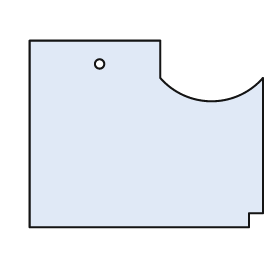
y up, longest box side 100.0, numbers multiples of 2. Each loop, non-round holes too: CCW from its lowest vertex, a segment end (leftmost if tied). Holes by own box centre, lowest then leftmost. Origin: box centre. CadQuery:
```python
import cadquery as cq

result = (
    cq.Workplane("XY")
    .moveTo(-50.0, -40.0)
    .lineTo(44.0, -40.0)
    .lineTo(44.0, -34.0)
    .lineTo(50.0, -34.0)
    .lineTo(50.0, 24.0)
    .threePointArc((28.0, 14.0), (6.0, 24.0))
    .lineTo(6.0, 40.0)
    .lineTo(-50.0, 40.0)
    .close()
    .moveTo(-20.0, 30.0)
    .circle(2.0)
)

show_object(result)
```